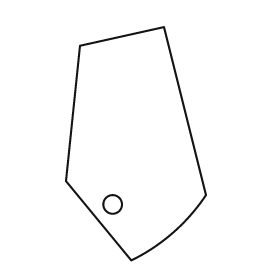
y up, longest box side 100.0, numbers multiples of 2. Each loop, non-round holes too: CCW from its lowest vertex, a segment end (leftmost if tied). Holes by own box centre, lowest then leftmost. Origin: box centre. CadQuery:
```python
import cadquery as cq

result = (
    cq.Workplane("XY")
    .moveTo(-2.0, -50.0)
    .threePointArc((16.0, -38.0), (30.0, -22.0))
    .lineTo(12.0, 50.0)
    .lineTo(-24.0, 42.0)
    .lineTo(-30.0, -16.0)
    .close()
    .moveTo(-10.0, -26.0)
    .circle(4.0)
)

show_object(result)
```